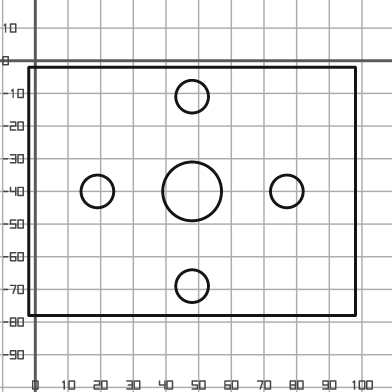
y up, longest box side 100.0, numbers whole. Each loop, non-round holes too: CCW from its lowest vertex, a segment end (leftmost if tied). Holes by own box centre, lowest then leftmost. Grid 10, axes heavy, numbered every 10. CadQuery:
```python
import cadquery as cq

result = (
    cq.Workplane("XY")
    .moveTo(-2.0, -78.0)
    .lineTo(98.0, -78.0)
    .lineTo(98.0, -2.0)
    .lineTo(-2.0, -2.0)
    .close()
    .moveTo(48.0, -69.0)
    .circle(5.0)
    .moveTo(19.0, -40.0)
    .circle(5.0)
    .moveTo(48.0, -40.0)
    .circle(9.0)
    .moveTo(77.0, -40.0)
    .circle(5.0)
    .moveTo(48.0, -11.0)
    .circle(5.0)
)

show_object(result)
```